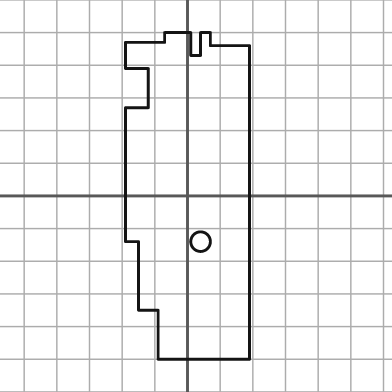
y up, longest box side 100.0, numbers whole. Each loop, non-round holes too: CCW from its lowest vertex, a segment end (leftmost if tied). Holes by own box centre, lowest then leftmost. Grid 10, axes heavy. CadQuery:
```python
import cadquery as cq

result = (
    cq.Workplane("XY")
    .moveTo(-9.0, -50.0)
    .lineTo(19.0, -50.0)
    .lineTo(19.0, 46.0)
    .lineTo(7.0, 46.0)
    .lineTo(7.0, 50.0)
    .lineTo(4.0, 50.0)
    .lineTo(4.0, 43.0)
    .lineTo(1.0, 43.0)
    .lineTo(1.0, 50.0)
    .lineTo(-7.0, 50.0)
    .lineTo(-7.0, 47.0)
    .lineTo(-19.0, 47.0)
    .lineTo(-19.0, 39.0)
    .lineTo(-12.0, 39.0)
    .lineTo(-12.0, 27.0)
    .lineTo(-19.0, 27.0)
    .lineTo(-19.0, -14.0)
    .lineTo(-15.0, -14.0)
    .lineTo(-15.0, -35.0)
    .lineTo(-9.0, -35.0)
    .close()
    .moveTo(4.0, -14.0)
    .circle(3.0)
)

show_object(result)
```